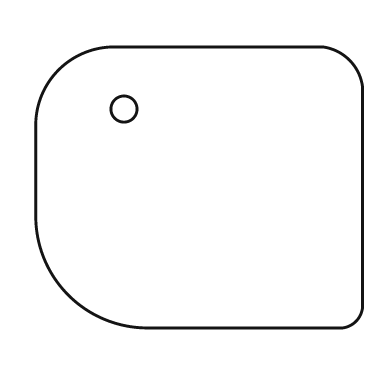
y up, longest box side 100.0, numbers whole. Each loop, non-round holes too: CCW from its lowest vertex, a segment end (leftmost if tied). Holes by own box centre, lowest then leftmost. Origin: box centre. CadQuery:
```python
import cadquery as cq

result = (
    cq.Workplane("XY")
    .moveTo(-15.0, -43.0)
    .lineTo(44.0, -43.0)
    .threePointArc((48.0, -41.0), (50.0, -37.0))
    .lineTo(50.0, 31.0)
    .threePointArc((46.0, 39.0), (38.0, 43.0))
    .lineTo(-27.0, 43.0)
    .threePointArc((-43.0, 36.0), (-50.0, 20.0))
    .lineTo(-50.0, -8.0)
    .threePointArc((-40.0, -33.0), (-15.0, -43.0))
    .close()
    .moveTo(-23.0, 24.0)
    .circle(4.0)
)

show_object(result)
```